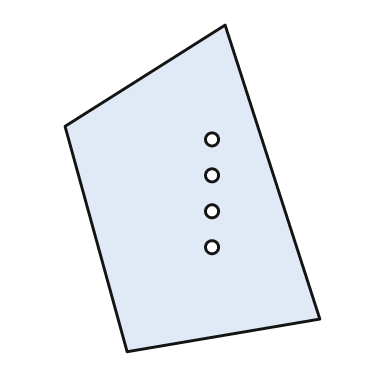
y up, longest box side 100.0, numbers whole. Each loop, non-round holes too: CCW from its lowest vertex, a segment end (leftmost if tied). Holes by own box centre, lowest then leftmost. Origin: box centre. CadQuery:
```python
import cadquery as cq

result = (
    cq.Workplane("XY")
    .moveTo(-20.0, -50.0)
    .lineTo(39.0, -40.0)
    .lineTo(10.0, 50.0)
    .lineTo(-39.0, 19.0)
    .close()
    .moveTo(6.0, -18.0)
    .circle(2.0)
    .moveTo(6.0, -7.0)
    .circle(2.0)
    .moveTo(6.0, 4.0)
    .circle(2.0)
    .moveTo(6.0, 15.0)
    .circle(2.0)
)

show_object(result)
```